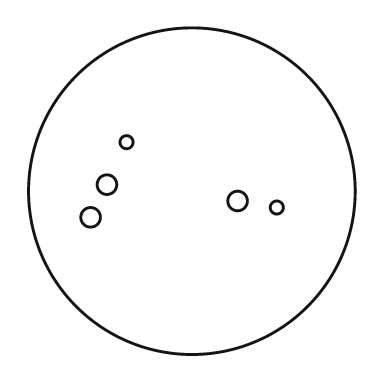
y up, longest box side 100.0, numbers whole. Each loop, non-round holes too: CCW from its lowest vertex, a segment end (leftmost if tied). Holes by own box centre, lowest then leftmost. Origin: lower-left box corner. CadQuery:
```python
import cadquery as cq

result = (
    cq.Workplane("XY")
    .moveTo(50.0, 50.0)
    .circle(50.0)
    .moveTo(19.0, 42.0)
    .circle(3.0)
    .moveTo(76.0, 45.0)
    .circle(2.0)
    .moveTo(64.0, 47.0)
    .circle(3.0)
    .moveTo(24.0, 52.0)
    .circle(3.0)
    .moveTo(30.0, 65.0)
    .circle(2.0)
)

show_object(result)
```